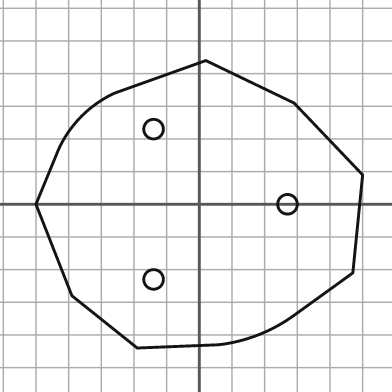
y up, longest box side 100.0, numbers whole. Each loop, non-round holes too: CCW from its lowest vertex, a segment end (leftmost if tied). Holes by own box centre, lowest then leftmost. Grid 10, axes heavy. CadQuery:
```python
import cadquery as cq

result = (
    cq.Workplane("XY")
    .moveTo(-19.0, -44.0)
    .lineTo(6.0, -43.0)
    .threePointArc((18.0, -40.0), (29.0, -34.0))
    .lineTo(47.0, -21.0)
    .lineTo(50.0, 9.0)
    .lineTo(29.0, 31.0)
    .lineTo(2.0, 44.0)
    .lineTo(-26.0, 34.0)
    .threePointArc((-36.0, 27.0), (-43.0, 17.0))
    .lineTo(-50.0, 0.0)
    .lineTo(-39.0, -28.0)
    .close()
    .moveTo(-14.0, -23.0)
    .circle(3.0)
    .moveTo(27.0, 0.0)
    .circle(3.0)
    .moveTo(-14.0, 23.0)
    .circle(3.0)
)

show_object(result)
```